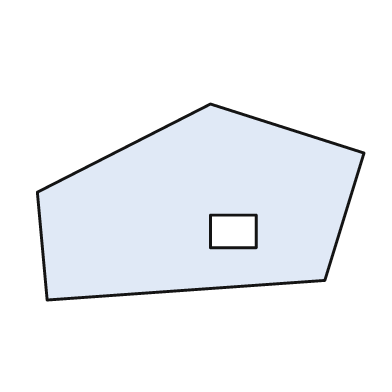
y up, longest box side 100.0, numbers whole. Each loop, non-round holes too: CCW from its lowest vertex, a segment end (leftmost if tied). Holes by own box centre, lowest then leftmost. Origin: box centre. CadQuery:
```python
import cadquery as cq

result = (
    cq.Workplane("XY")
    .moveTo(-47.0, -30.0)
    .lineTo(38.0, -24.0)
    .lineTo(50.0, 15.0)
    .lineTo(3.0, 30.0)
    .lineTo(-50.0, 3.0)
    .close()
    .moveTo(3.0, -14.0)
    .lineTo(17.0, -14.0)
    .lineTo(17.0, -4.0)
    .lineTo(3.0, -4.0)
    .close()
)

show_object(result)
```